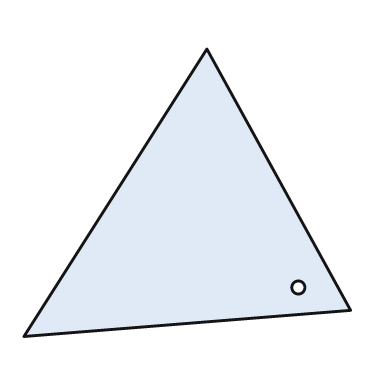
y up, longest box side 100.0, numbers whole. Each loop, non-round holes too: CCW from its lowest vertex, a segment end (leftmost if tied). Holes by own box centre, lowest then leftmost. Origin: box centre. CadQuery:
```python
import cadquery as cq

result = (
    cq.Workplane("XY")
    .moveTo(-50.0, -44.0)
    .lineTo(50.0, -36.0)
    .lineTo(6.0, 44.0)
    .close()
    .moveTo(34.0, -29.0)
    .circle(2.0)
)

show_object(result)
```